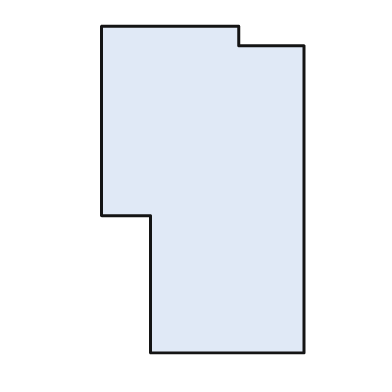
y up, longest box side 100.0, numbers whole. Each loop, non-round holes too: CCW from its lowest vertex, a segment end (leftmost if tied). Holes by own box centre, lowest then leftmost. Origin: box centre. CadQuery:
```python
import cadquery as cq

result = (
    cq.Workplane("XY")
    .moveTo(-16.0, -50.0)
    .lineTo(31.0, -50.0)
    .lineTo(31.0, 44.0)
    .lineTo(11.0, 44.0)
    .lineTo(11.0, 50.0)
    .lineTo(-31.0, 50.0)
    .lineTo(-31.0, -8.0)
    .lineTo(-16.0, -8.0)
    .close()
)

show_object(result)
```